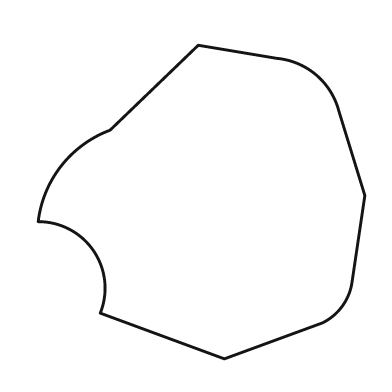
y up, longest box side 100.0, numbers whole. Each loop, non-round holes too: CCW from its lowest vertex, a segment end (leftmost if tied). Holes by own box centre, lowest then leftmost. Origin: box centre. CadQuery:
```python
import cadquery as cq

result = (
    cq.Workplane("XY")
    .moveTo(7.0, -48.0)
    .lineTo(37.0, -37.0)
    .threePointArc((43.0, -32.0), (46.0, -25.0))
    .lineTo(50.0, 2.0)
    .lineTo(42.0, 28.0)
    .threePointArc((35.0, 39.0), (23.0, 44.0))
    .lineTo(-1.0, 48.0)
    .lineTo(-28.0, 22.0)
    .threePointArc((-43.0, 11.0), (-50.0, -6.0))
    .threePointArc((-33.0, -15.0), (-31.0, -34.0))
    .close()
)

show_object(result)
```